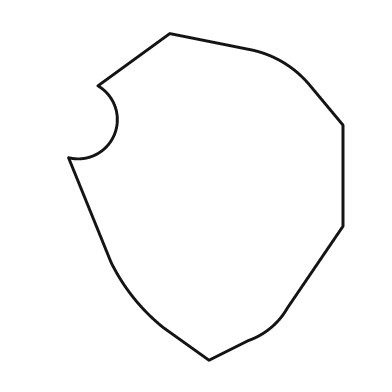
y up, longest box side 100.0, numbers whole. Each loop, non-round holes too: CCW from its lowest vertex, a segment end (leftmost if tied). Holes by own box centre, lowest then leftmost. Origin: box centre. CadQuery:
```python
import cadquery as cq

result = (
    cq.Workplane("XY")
    .moveTo(1.0, -50.0)
    .lineTo(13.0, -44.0)
    .threePointArc((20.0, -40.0), (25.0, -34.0))
    .lineTo(42.0, -9.0)
    .lineTo(42.0, 22.0)
    .lineTo(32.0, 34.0)
    .threePointArc((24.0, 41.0), (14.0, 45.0))
    .lineTo(-11.0, 50.0)
    .lineTo(-33.0, 34.0)
    .threePointArc((-28.0, 19.0), (-42.0, 12.0))
    .lineTo(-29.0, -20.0)
    .threePointArc((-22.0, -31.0), (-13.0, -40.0))
    .close()
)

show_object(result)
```